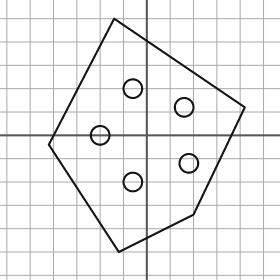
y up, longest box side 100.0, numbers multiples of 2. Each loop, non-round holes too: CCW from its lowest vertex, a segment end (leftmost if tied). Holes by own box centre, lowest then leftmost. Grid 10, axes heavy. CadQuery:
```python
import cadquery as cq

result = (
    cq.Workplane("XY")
    .moveTo(-12.0, -50.0)
    .lineTo(20.0, -34.0)
    .lineTo(42.0, 12.0)
    .lineTo(-14.0, 50.0)
    .lineTo(-42.0, -4.0)
    .close()
    .moveTo(-6.0, -20.0)
    .circle(4.0)
    .moveTo(18.0, -12.0)
    .circle(4.0)
    .moveTo(-20.0, 0.0)
    .circle(4.0)
    .moveTo(16.0, 12.0)
    .circle(4.0)
    .moveTo(-6.0, 20.0)
    .circle(4.0)
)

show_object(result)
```